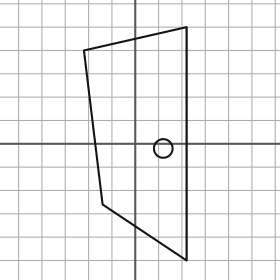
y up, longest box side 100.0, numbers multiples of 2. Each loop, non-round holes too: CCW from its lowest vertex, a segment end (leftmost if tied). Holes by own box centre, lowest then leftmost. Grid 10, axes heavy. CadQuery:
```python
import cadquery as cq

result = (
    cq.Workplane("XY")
    .moveTo(22.0, -50.0)
    .lineTo(22.0, 50.0)
    .lineTo(-22.0, 40.0)
    .lineTo(-14.0, -26.0)
    .close()
    .moveTo(12.0, -2.0)
    .circle(4.0)
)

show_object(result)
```